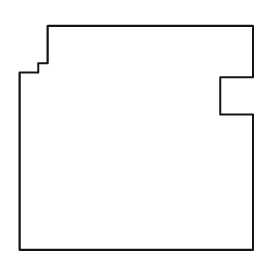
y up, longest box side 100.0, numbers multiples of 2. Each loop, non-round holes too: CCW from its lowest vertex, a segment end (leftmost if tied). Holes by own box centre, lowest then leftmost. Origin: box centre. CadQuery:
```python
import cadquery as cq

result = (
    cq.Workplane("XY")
    .moveTo(-50.0, -48.0)
    .lineTo(50.0, -48.0)
    .lineTo(50.0, 10.0)
    .lineTo(36.0, 10.0)
    .lineTo(36.0, 26.0)
    .lineTo(50.0, 26.0)
    .lineTo(50.0, 48.0)
    .lineTo(-38.0, 48.0)
    .lineTo(-38.0, 32.0)
    .lineTo(-42.0, 32.0)
    .lineTo(-42.0, 28.0)
    .lineTo(-50.0, 28.0)
    .close()
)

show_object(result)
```